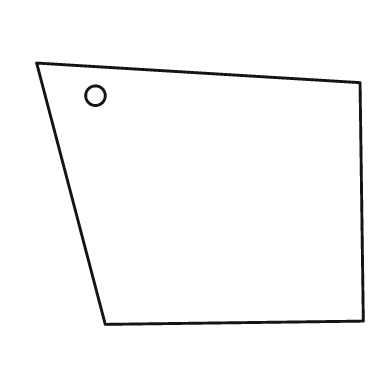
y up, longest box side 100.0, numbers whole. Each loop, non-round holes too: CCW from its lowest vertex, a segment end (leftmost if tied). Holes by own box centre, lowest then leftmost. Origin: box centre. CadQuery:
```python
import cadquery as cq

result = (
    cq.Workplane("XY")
    .moveTo(-29.0, -40.0)
    .lineTo(50.0, -39.0)
    .lineTo(49.0, 34.0)
    .lineTo(-50.0, 40.0)
    .close()
    .moveTo(-32.0, 30.0)
    .circle(3.0)
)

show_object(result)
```